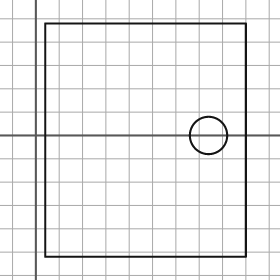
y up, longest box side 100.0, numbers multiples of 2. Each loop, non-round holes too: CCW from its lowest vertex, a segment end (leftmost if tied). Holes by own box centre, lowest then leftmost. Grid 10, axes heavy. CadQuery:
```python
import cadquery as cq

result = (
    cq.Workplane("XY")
    .moveTo(4.0, -52.0)
    .lineTo(90.0, -52.0)
    .lineTo(90.0, 48.0)
    .lineTo(4.0, 48.0)
    .close()
    .moveTo(74.0, 0.0)
    .circle(8.0)
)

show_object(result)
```